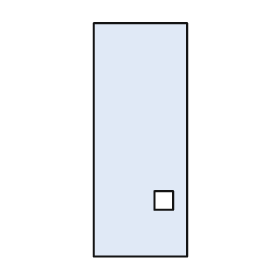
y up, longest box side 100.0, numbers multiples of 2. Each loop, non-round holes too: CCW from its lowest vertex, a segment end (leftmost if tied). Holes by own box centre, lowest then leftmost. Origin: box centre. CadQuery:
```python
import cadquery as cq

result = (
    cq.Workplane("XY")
    .moveTo(-20.0, -50.0)
    .lineTo(20.0, -50.0)
    .lineTo(20.0, 50.0)
    .lineTo(-20.0, 50.0)
    .close()
    .moveTo(6.0, -30.0)
    .lineTo(14.0, -30.0)
    .lineTo(14.0, -22.0)
    .lineTo(6.0, -22.0)
    .close()
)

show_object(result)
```